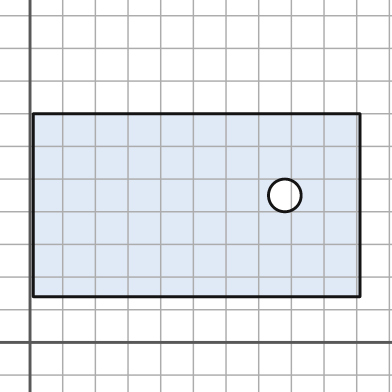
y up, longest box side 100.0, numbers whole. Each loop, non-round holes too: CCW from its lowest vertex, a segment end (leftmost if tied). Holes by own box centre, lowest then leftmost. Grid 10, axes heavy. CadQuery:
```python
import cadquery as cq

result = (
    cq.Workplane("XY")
    .moveTo(1.0, 14.0)
    .lineTo(101.0, 14.0)
    .lineTo(101.0, 70.0)
    .lineTo(1.0, 70.0)
    .close()
    .moveTo(78.0, 45.0)
    .circle(5.0)
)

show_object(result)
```